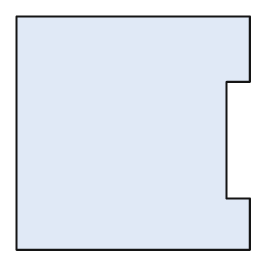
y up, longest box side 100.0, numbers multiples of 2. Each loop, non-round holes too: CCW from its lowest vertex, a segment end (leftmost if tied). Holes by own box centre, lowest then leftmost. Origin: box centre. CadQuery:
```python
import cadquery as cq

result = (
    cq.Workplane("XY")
    .moveTo(-50.0, -50.0)
    .lineTo(50.0, -50.0)
    .lineTo(50.0, -28.0)
    .lineTo(40.0, -28.0)
    .lineTo(40.0, 22.0)
    .lineTo(50.0, 22.0)
    .lineTo(50.0, 50.0)
    .lineTo(-50.0, 50.0)
    .close()
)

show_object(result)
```